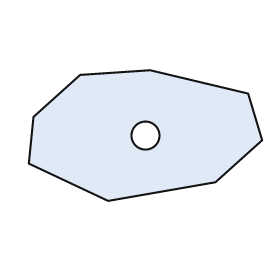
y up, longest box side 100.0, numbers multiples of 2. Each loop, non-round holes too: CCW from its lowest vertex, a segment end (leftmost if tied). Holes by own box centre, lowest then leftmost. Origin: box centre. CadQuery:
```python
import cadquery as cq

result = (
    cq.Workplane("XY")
    .moveTo(-16.0, -28.0)
    .lineTo(30.0, -20.0)
    .lineTo(50.0, -2.0)
    .lineTo(44.0, 18.0)
    .lineTo(2.0, 28.0)
    .lineTo(-28.0, 26.0)
    .lineTo(-48.0, 8.0)
    .lineTo(-50.0, -12.0)
    .close()
    .moveTo(0.0, 0.0)
    .circle(6.0)
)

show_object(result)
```